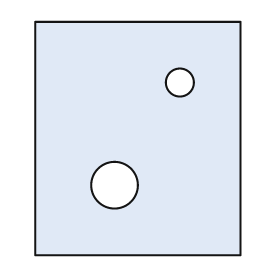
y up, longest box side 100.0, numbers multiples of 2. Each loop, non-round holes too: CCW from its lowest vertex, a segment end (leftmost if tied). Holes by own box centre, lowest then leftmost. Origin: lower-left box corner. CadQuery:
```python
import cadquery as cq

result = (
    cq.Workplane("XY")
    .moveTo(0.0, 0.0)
    .lineTo(88.0, 0.0)
    .lineTo(88.0, 100.0)
    .lineTo(0.0, 100.0)
    .close()
    .moveTo(34.0, 30.0)
    .circle(10.0)
    .moveTo(62.0, 74.0)
    .circle(6.0)
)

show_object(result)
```